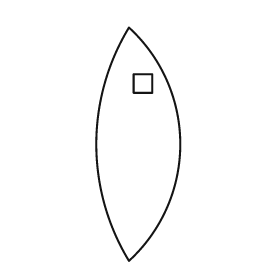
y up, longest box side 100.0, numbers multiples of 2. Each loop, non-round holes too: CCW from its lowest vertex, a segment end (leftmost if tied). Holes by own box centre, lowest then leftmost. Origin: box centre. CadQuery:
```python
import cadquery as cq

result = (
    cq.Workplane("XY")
    .moveTo(-4.0, -50.0)
    .threePointArc((18.0, 0.0), (-4.0, 50.0))
    .threePointArc((-18.0, 0.0), (-4.0, -50.0))
    .close()
    .moveTo(-2.0, 22.0)
    .lineTo(6.0, 22.0)
    .lineTo(6.0, 30.0)
    .lineTo(-2.0, 30.0)
    .close()
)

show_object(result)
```